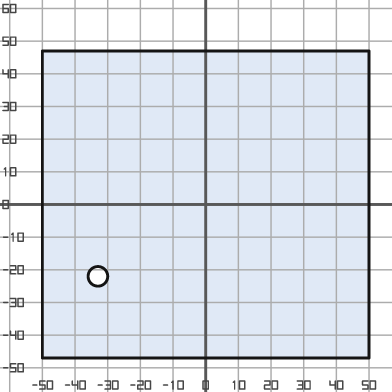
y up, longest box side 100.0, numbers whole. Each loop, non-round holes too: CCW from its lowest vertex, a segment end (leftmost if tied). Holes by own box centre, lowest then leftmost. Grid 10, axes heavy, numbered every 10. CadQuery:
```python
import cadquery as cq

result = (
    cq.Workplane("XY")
    .moveTo(-50.0, -47.0)
    .lineTo(50.0, -47.0)
    .lineTo(50.0, 47.0)
    .lineTo(-50.0, 47.0)
    .close()
    .moveTo(-33.0, -22.0)
    .circle(3.0)
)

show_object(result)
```